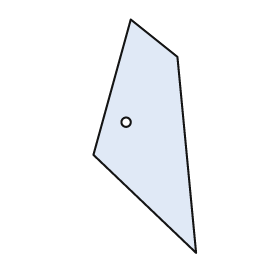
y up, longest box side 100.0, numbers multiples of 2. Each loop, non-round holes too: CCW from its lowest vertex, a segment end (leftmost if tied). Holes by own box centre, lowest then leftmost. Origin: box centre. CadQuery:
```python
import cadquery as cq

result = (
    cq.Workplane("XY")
    .moveTo(22.0, -50.0)
    .lineTo(14.0, 34.0)
    .lineTo(-6.0, 50.0)
    .lineTo(-22.0, -8.0)
    .close()
    .moveTo(-8.0, 6.0)
    .circle(2.0)
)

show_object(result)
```